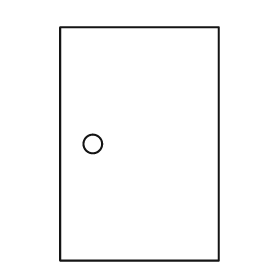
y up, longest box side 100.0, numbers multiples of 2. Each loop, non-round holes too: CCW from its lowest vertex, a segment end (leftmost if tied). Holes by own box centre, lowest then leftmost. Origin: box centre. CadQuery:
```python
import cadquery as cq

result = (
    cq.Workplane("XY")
    .moveTo(-34.0, -50.0)
    .lineTo(34.0, -50.0)
    .lineTo(34.0, 50.0)
    .lineTo(-34.0, 50.0)
    .close()
    .moveTo(-20.0, 0.0)
    .circle(4.0)
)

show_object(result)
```